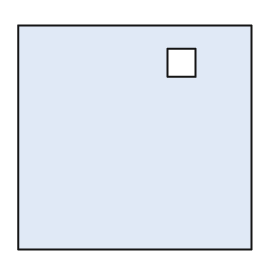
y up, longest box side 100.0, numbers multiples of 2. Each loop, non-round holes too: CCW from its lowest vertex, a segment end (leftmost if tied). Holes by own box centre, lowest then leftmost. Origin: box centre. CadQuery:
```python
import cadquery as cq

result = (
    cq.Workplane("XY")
    .moveTo(-50.0, -48.0)
    .lineTo(50.0, -48.0)
    .lineTo(50.0, 48.0)
    .lineTo(-50.0, 48.0)
    .close()
    .moveTo(14.0, 26.0)
    .lineTo(26.0, 26.0)
    .lineTo(26.0, 38.0)
    .lineTo(14.0, 38.0)
    .close()
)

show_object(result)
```